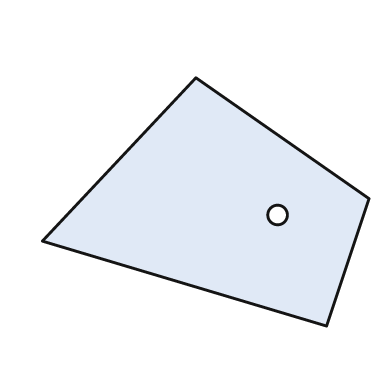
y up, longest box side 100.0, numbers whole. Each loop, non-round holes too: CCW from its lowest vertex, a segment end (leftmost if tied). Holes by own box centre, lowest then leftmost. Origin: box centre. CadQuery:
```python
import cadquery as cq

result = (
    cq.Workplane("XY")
    .moveTo(37.0, -38.0)
    .lineTo(50.0, 1.0)
    .lineTo(-3.0, 38.0)
    .lineTo(-50.0, -12.0)
    .close()
    .moveTo(22.0, -4.0)
    .circle(3.0)
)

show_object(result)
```